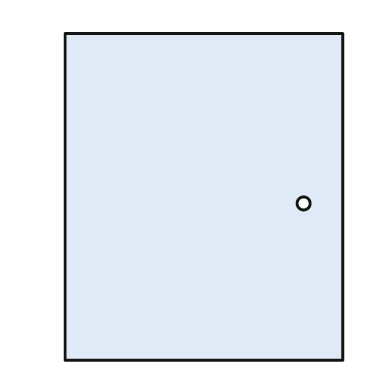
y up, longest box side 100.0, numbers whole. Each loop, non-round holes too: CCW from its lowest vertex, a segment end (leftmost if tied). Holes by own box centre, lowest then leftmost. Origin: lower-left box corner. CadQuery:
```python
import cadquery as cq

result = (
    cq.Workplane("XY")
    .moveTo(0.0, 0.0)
    .lineTo(85.0, 0.0)
    .lineTo(85.0, 100.0)
    .lineTo(0.0, 100.0)
    .close()
    .moveTo(73.0, 48.0)
    .circle(2.0)
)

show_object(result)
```